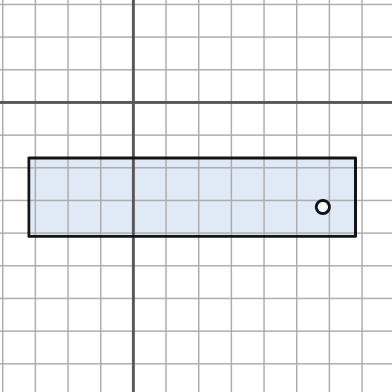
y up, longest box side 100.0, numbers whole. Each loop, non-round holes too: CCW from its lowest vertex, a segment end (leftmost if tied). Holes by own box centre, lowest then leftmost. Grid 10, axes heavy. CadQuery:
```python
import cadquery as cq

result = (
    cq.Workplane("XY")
    .moveTo(-32.0, -41.0)
    .lineTo(68.0, -41.0)
    .lineTo(68.0, -17.0)
    .lineTo(-32.0, -17.0)
    .close()
    .moveTo(58.0, -32.0)
    .circle(2.0)
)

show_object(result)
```